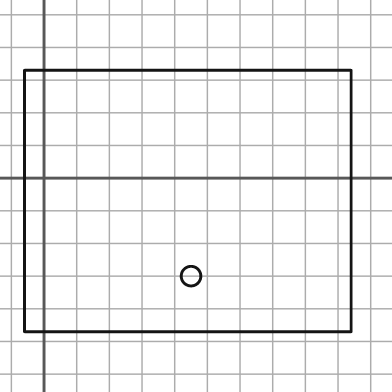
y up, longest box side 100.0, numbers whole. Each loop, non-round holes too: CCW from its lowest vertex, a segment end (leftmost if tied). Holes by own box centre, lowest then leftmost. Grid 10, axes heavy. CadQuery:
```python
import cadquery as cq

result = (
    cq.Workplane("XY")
    .moveTo(-6.0, -47.0)
    .lineTo(94.0, -47.0)
    .lineTo(94.0, 33.0)
    .lineTo(-6.0, 33.0)
    .close()
    .moveTo(45.0, -30.0)
    .circle(3.0)
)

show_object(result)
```